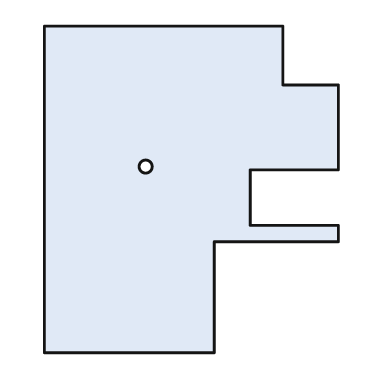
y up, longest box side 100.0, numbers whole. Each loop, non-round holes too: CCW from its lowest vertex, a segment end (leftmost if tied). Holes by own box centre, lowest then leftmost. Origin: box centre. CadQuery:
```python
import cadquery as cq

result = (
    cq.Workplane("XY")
    .moveTo(-45.0, -50.0)
    .lineTo(7.0, -50.0)
    .lineTo(7.0, -16.0)
    .lineTo(45.0, -16.0)
    .lineTo(45.0, -11.0)
    .lineTo(18.0, -11.0)
    .lineTo(18.0, 6.0)
    .lineTo(45.0, 6.0)
    .lineTo(45.0, 32.0)
    .lineTo(28.0, 32.0)
    .lineTo(28.0, 50.0)
    .lineTo(-45.0, 50.0)
    .close()
    .moveTo(-14.0, 7.0)
    .circle(2.0)
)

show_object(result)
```